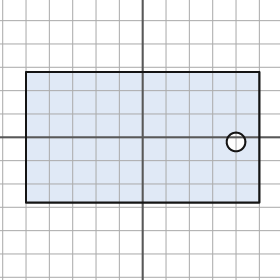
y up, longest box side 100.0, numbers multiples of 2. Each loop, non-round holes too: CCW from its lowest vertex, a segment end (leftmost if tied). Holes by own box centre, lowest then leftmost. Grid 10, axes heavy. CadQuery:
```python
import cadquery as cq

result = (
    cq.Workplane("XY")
    .moveTo(-50.0, -28.0)
    .lineTo(50.0, -28.0)
    .lineTo(50.0, 28.0)
    .lineTo(-50.0, 28.0)
    .close()
    .moveTo(40.0, -2.0)
    .circle(4.0)
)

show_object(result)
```